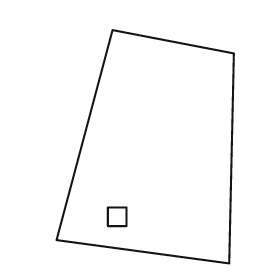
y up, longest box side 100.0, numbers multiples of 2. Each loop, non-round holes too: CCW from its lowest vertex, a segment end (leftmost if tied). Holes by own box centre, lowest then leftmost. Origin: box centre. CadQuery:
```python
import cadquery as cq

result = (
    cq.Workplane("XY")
    .moveTo(36.0, -50.0)
    .lineTo(38.0, 40.0)
    .lineTo(-14.0, 50.0)
    .lineTo(-38.0, -40.0)
    .close()
    .moveTo(-16.0, -34.0)
    .lineTo(-8.0, -34.0)
    .lineTo(-8.0, -26.0)
    .lineTo(-16.0, -26.0)
    .close()
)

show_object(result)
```